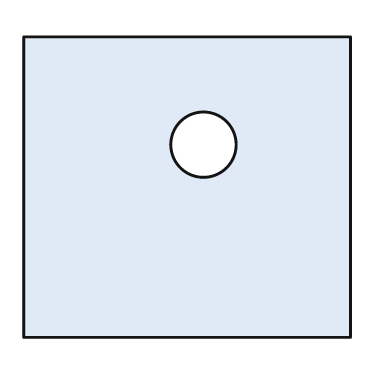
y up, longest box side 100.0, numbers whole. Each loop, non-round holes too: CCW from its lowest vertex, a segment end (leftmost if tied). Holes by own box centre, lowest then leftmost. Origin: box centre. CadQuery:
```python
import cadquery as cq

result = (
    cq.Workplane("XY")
    .moveTo(-50.0, -46.0)
    .lineTo(50.0, -46.0)
    .lineTo(50.0, 46.0)
    .lineTo(-50.0, 46.0)
    .close()
    .moveTo(5.0, 13.0)
    .circle(10.0)
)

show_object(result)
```